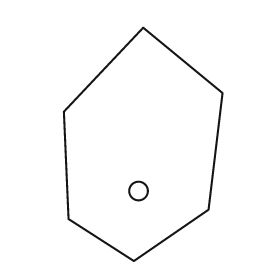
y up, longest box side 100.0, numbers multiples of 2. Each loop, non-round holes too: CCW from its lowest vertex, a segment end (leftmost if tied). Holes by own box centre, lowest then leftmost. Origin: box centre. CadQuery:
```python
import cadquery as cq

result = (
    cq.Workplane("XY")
    .moveTo(-4.0, -50.0)
    .lineTo(28.0, -28.0)
    .lineTo(34.0, 22.0)
    .lineTo(0.0, 50.0)
    .lineTo(-34.0, 14.0)
    .lineTo(-32.0, -32.0)
    .close()
    .moveTo(-2.0, -20.0)
    .circle(4.0)
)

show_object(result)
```